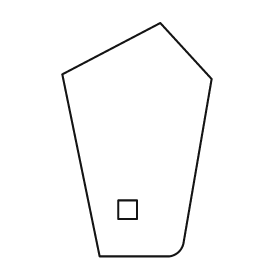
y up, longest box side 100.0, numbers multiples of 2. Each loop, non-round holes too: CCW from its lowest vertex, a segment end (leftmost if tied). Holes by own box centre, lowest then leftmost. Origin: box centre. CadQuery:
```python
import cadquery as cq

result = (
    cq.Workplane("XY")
    .moveTo(-16.0, -50.0)
    .lineTo(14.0, -50.0)
    .threePointArc((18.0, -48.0), (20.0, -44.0))
    .lineTo(32.0, 26.0)
    .lineTo(10.0, 50.0)
    .lineTo(-32.0, 28.0)
    .close()
    .moveTo(-8.0, -34.0)
    .lineTo(0.0, -34.0)
    .lineTo(0.0, -26.0)
    .lineTo(-8.0, -26.0)
    .close()
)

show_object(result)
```